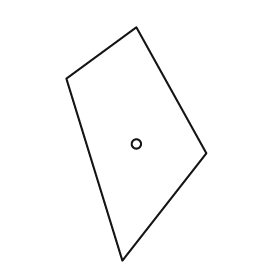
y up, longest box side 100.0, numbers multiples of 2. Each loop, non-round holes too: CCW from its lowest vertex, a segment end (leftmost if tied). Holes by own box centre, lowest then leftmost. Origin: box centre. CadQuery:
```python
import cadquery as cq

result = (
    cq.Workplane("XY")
    .moveTo(-6.0, -50.0)
    .lineTo(30.0, -4.0)
    .lineTo(0.0, 50.0)
    .lineTo(-30.0, 28.0)
    .close()
    .moveTo(0.0, 0.0)
    .circle(2.0)
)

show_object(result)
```